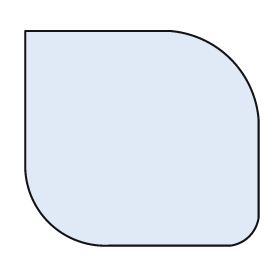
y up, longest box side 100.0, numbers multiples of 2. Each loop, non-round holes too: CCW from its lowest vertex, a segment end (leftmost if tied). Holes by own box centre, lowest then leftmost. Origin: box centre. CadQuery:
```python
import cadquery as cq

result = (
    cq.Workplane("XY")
    .moveTo(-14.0, -46.0)
    .lineTo(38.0, -46.0)
    .threePointArc((46.0, -42.0), (50.0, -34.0))
    .lineTo(50.0, 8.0)
    .threePointArc((38.0, 34.0), (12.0, 46.0))
    .lineTo(-50.0, 46.0)
    .lineTo(-50.0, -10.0)
    .threePointArc((-40.0, -36.0), (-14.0, -46.0))
    .close()
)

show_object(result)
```